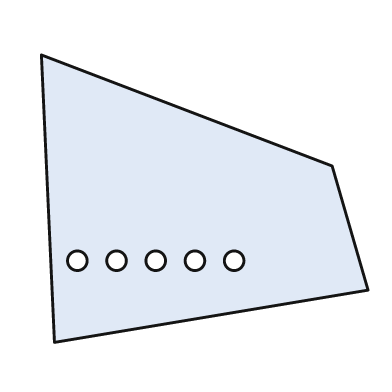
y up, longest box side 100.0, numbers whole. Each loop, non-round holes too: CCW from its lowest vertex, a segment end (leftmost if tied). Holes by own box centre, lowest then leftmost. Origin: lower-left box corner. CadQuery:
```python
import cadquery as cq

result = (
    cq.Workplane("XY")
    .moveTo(4.0, 0.0)
    .lineTo(100.0, 16.0)
    .lineTo(89.0, 54.0)
    .lineTo(0.0, 88.0)
    .close()
    .moveTo(11.0, 25.0)
    .circle(3.0)
    .moveTo(23.0, 25.0)
    .circle(3.0)
    .moveTo(35.0, 25.0)
    .circle(3.0)
    .moveTo(47.0, 25.0)
    .circle(3.0)
    .moveTo(59.0, 25.0)
    .circle(3.0)
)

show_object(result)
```